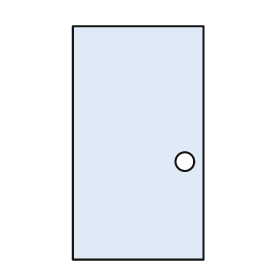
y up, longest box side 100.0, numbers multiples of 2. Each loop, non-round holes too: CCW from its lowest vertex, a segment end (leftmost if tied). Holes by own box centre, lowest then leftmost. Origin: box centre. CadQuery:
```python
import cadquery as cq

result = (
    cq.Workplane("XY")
    .moveTo(-28.0, -50.0)
    .lineTo(28.0, -50.0)
    .lineTo(28.0, 50.0)
    .lineTo(-28.0, 50.0)
    .close()
    .moveTo(20.0, -8.0)
    .circle(4.0)
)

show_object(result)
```